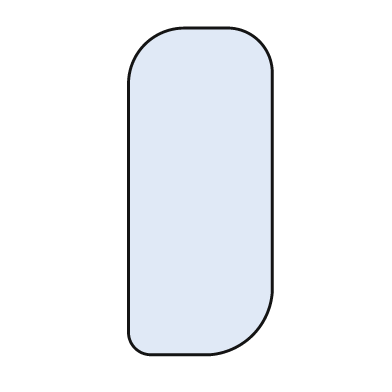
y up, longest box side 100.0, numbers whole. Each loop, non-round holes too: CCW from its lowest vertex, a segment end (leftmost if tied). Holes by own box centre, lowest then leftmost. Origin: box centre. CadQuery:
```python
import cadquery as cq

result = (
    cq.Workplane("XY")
    .moveTo(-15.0, -50.0)
    .lineTo(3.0, -50.0)
    .threePointArc((16.0, -44.0), (22.0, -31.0))
    .lineTo(22.0, 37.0)
    .threePointArc((18.0, 46.0), (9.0, 50.0))
    .lineTo(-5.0, 50.0)
    .threePointArc((-17.0, 45.0), (-22.0, 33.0))
    .lineTo(-22.0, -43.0)
    .threePointArc((-20.0, -48.0), (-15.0, -50.0))
    .close()
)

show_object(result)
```